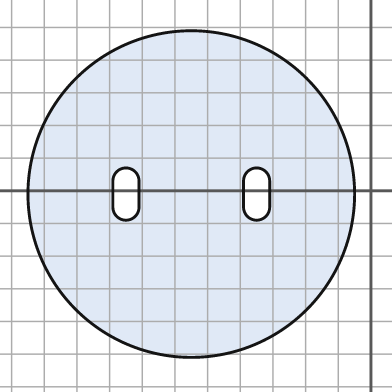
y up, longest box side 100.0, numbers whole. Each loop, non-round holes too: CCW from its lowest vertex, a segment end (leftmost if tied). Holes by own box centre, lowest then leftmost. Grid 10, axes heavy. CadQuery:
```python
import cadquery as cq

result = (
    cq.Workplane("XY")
    .moveTo(-55.0, -1.0)
    .circle(50.0)
    .moveTo(-79.0, -5.0)
    .threePointArc((-75.0, -9.0), (-71.0, -5.0))
    .lineTo(-71.0, 3.0)
    .threePointArc((-75.0, 7.0), (-79.0, 3.0))
    .close()
    .moveTo(-39.0, -5.0)
    .threePointArc((-35.0, -9.0), (-31.0, -5.0))
    .lineTo(-31.0, 3.0)
    .threePointArc((-35.0, 7.0), (-39.0, 3.0))
    .close()
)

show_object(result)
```